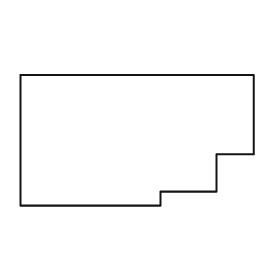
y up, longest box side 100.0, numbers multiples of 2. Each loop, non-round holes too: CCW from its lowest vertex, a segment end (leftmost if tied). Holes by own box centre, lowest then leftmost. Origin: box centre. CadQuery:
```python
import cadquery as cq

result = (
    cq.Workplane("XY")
    .moveTo(-50.0, -28.0)
    .lineTo(10.0, -28.0)
    .lineTo(10.0, -22.0)
    .lineTo(34.0, -22.0)
    .lineTo(34.0, -6.0)
    .lineTo(50.0, -6.0)
    .lineTo(50.0, 28.0)
    .lineTo(-50.0, 28.0)
    .close()
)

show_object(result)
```